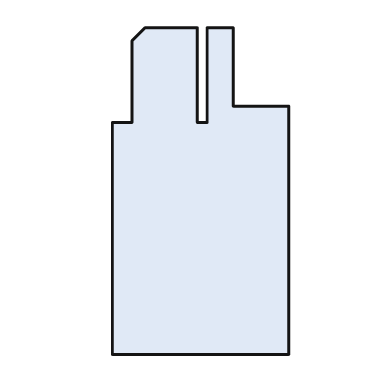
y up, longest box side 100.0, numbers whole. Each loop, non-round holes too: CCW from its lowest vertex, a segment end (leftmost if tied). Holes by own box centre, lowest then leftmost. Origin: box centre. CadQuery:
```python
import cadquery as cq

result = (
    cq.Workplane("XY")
    .moveTo(-27.0, -50.0)
    .lineTo(27.0, -50.0)
    .lineTo(27.0, 26.0)
    .lineTo(10.0, 26.0)
    .lineTo(10.0, 50.0)
    .lineTo(2.0, 50.0)
    .lineTo(2.0, 21.0)
    .lineTo(-1.0, 21.0)
    .lineTo(-1.0, 50.0)
    .lineTo(-17.0, 50.0)
    .lineTo(-21.0, 46.0)
    .lineTo(-21.0, 21.0)
    .lineTo(-27.0, 21.0)
    .close()
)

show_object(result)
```